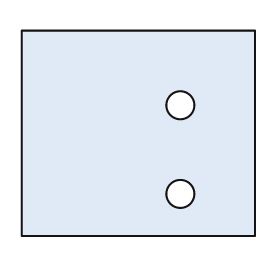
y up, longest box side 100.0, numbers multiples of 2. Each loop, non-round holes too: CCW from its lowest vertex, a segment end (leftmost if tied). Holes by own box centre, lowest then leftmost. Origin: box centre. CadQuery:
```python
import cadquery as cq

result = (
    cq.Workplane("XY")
    .moveTo(-50.0, -44.0)
    .lineTo(50.0, -44.0)
    .lineTo(50.0, 44.0)
    .lineTo(-50.0, 44.0)
    .close()
    .moveTo(18.0, -26.0)
    .circle(6.0)
    .moveTo(18.0, 12.0)
    .circle(6.0)
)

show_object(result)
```